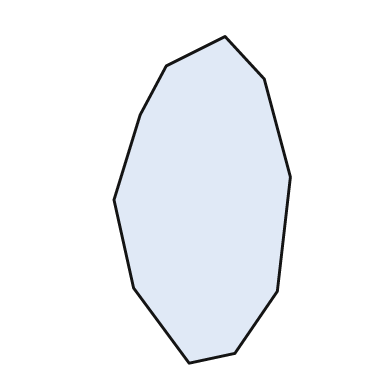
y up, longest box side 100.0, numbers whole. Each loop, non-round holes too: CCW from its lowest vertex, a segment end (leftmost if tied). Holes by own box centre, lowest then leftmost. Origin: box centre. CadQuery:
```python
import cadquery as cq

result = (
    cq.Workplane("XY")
    .moveTo(-4.0, -50.0)
    .lineTo(10.0, -47.0)
    .lineTo(23.0, -28.0)
    .lineTo(27.0, 7.0)
    .lineTo(19.0, 37.0)
    .lineTo(7.0, 50.0)
    .lineTo(-11.0, 41.0)
    .lineTo(-19.0, 26.0)
    .lineTo(-27.0, 0.0)
    .lineTo(-21.0, -27.0)
    .close()
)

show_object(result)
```